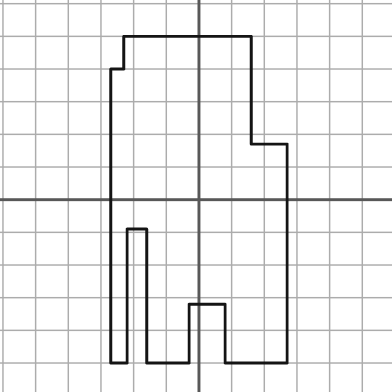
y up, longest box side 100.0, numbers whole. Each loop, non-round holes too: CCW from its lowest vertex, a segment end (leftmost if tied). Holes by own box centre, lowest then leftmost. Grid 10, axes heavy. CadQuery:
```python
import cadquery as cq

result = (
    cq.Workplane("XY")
    .moveTo(-27.0, -50.0)
    .lineTo(-22.0, -50.0)
    .lineTo(-22.0, -9.0)
    .lineTo(-16.0, -9.0)
    .lineTo(-16.0, -50.0)
    .lineTo(-3.0, -50.0)
    .lineTo(-3.0, -32.0)
    .lineTo(8.0, -32.0)
    .lineTo(8.0, -50.0)
    .lineTo(27.0, -50.0)
    .lineTo(27.0, 17.0)
    .lineTo(16.0, 17.0)
    .lineTo(16.0, 50.0)
    .lineTo(-23.0, 50.0)
    .lineTo(-23.0, 40.0)
    .lineTo(-27.0, 40.0)
    .close()
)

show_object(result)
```